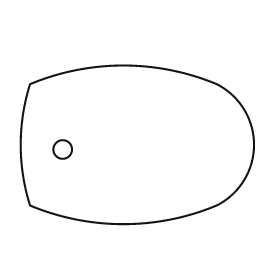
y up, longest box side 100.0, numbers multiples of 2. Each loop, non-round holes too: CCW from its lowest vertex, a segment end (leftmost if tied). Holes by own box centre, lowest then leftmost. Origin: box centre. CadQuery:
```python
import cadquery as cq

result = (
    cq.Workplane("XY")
    .moveTo(-46.0, -26.0)
    .threePointArc((-6.0, -34.0), (34.0, -26.0))
    .threePointArc((50.0, 0.0), (34.0, 26.0))
    .threePointArc((-6.0, 34.0), (-46.0, 26.0))
    .threePointArc((-50.0, 0.0), (-46.0, -26.0))
    .close()
    .moveTo(-32.0, -2.0)
    .circle(4.0)
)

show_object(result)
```